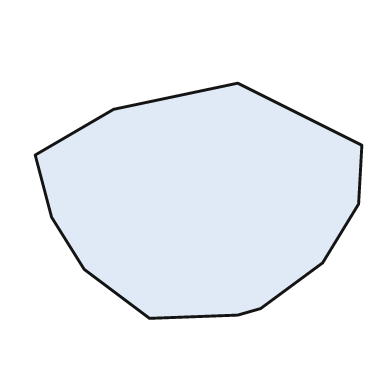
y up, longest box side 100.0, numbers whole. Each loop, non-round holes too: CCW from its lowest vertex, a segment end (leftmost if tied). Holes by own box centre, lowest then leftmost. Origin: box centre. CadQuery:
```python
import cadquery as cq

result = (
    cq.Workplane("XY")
    .moveTo(-15.0, -36.0)
    .lineTo(12.0, -35.0)
    .lineTo(19.0, -33.0)
    .lineTo(38.0, -19.0)
    .lineTo(49.0, -1.0)
    .lineTo(50.0, 17.0)
    .lineTo(12.0, 36.0)
    .lineTo(-26.0, 28.0)
    .lineTo(-50.0, 14.0)
    .lineTo(-45.0, -5.0)
    .lineTo(-35.0, -21.0)
    .close()
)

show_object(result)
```